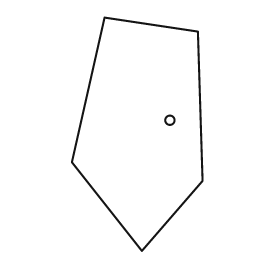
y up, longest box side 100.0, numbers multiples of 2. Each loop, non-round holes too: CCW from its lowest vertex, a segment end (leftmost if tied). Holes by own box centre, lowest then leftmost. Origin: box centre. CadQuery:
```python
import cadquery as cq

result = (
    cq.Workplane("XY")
    .moveTo(2.0, -50.0)
    .lineTo(28.0, -20.0)
    .lineTo(26.0, 44.0)
    .lineTo(-14.0, 50.0)
    .lineTo(-28.0, -12.0)
    .close()
    .moveTo(14.0, 6.0)
    .circle(2.0)
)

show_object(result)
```